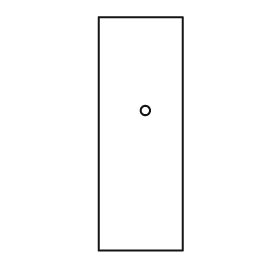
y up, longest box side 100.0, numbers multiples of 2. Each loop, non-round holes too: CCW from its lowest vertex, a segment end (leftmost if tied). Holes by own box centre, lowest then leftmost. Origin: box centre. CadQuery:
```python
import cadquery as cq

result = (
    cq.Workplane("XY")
    .moveTo(-18.0, -50.0)
    .lineTo(18.0, -50.0)
    .lineTo(18.0, 50.0)
    .lineTo(-18.0, 50.0)
    .close()
    .moveTo(2.0, 10.0)
    .circle(2.0)
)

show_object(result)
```